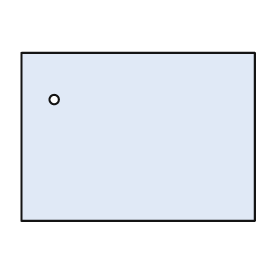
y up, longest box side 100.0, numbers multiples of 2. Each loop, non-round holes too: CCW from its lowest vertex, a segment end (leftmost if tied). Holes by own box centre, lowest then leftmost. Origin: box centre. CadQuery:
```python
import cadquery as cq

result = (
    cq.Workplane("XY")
    .moveTo(-50.0, -36.0)
    .lineTo(50.0, -36.0)
    .lineTo(50.0, 36.0)
    .lineTo(-50.0, 36.0)
    .close()
    .moveTo(-36.0, 16.0)
    .circle(2.0)
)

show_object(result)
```